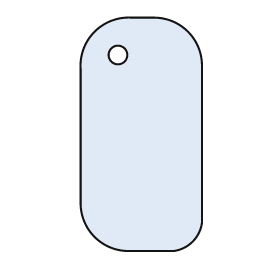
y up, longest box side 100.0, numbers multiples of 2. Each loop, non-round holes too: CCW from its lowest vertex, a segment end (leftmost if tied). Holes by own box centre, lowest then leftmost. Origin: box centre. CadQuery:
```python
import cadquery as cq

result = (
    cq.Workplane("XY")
    .moveTo(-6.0, -50.0)
    .lineTo(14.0, -50.0)
    .threePointArc((22.0, -46.0), (26.0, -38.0))
    .lineTo(26.0, 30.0)
    .threePointArc((20.0, 44.0), (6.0, 50.0))
    .lineTo(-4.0, 50.0)
    .threePointArc((-20.0, 44.0), (-26.0, 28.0))
    .lineTo(-26.0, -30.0)
    .threePointArc((-20.0, -44.0), (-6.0, -50.0))
    .close()
    .moveTo(-10.0, 34.0)
    .circle(4.0)
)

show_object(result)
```